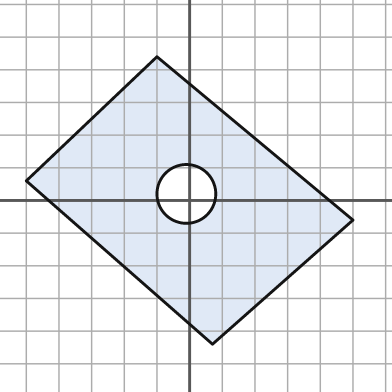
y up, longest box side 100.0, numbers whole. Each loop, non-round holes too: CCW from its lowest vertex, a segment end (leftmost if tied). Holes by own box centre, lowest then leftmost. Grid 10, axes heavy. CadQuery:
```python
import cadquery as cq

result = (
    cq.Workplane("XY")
    .moveTo(7.0, -44.0)
    .lineTo(50.0, -6.0)
    .lineTo(-10.0, 44.0)
    .lineTo(-50.0, 6.0)
    .close()
    .moveTo(-1.0, 2.0)
    .circle(9.0)
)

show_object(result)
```